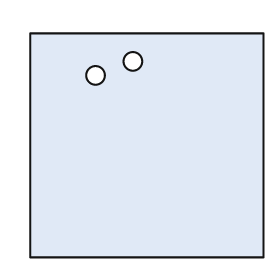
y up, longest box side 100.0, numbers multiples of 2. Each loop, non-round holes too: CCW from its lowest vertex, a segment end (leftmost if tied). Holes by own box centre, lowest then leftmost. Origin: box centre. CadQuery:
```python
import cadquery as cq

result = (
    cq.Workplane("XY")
    .moveTo(-50.0, -48.0)
    .lineTo(50.0, -48.0)
    .lineTo(50.0, 48.0)
    .lineTo(-50.0, 48.0)
    .close()
    .moveTo(-22.0, 30.0)
    .circle(4.0)
    .moveTo(-6.0, 36.0)
    .circle(4.0)
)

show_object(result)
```